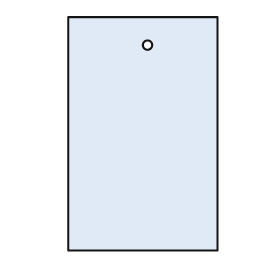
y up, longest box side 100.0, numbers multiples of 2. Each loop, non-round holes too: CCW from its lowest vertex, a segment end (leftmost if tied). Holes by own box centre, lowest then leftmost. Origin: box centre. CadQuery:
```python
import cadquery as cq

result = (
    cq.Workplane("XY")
    .moveTo(-32.0, -50.0)
    .lineTo(32.0, -50.0)
    .lineTo(32.0, 50.0)
    .lineTo(-32.0, 50.0)
    .close()
    .moveTo(2.0, 38.0)
    .circle(2.0)
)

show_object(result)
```